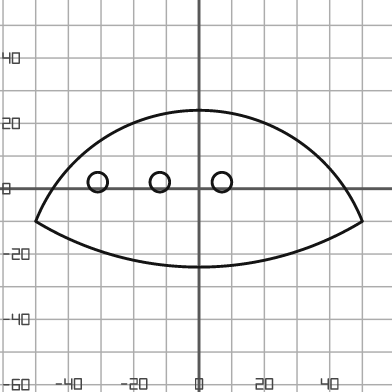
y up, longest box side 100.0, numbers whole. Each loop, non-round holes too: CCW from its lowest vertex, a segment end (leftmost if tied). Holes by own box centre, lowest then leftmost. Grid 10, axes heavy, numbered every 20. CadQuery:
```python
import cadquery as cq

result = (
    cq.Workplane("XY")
    .moveTo(-50.0, -10.0)
    .threePointArc((0.0, -24.0), (50.0, -10.0))
    .threePointArc((0.0, 24.0), (-50.0, -10.0))
    .close()
    .moveTo(-31.0, 2.0)
    .circle(3.0)
    .moveTo(-12.0, 2.0)
    .circle(3.0)
    .moveTo(7.0, 2.0)
    .circle(3.0)
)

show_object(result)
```